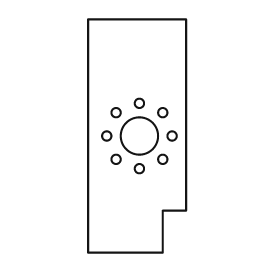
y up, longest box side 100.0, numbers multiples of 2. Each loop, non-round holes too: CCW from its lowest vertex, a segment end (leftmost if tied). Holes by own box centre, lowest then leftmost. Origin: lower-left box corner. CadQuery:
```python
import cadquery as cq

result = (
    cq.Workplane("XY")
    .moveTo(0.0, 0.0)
    .lineTo(32.0, 0.0)
    .lineTo(32.0, 18.0)
    .lineTo(42.0, 18.0)
    .lineTo(42.0, 100.0)
    .lineTo(0.0, 100.0)
    .close()
    .moveTo(22.0, 36.0)
    .circle(2.0)
    .moveTo(12.0, 40.0)
    .circle(2.0)
    .moveTo(32.0, 40.0)
    .circle(2.0)
    .moveTo(8.0, 50.0)
    .circle(2.0)
    .moveTo(22.0, 50.0)
    .circle(8.0)
    .moveTo(36.0, 50.0)
    .circle(2.0)
    .moveTo(12.0, 60.0)
    .circle(2.0)
    .moveTo(32.0, 60.0)
    .circle(2.0)
    .moveTo(22.0, 64.0)
    .circle(2.0)
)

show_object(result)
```